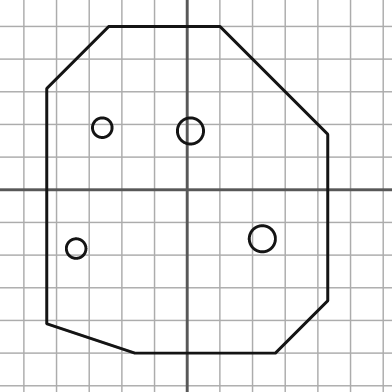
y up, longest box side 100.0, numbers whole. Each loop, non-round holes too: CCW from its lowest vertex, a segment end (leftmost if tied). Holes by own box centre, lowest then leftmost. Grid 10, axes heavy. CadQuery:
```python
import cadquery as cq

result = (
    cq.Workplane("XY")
    .moveTo(-16.0, -50.0)
    .lineTo(27.0, -50.0)
    .lineTo(43.0, -34.0)
    .lineTo(43.0, 17.0)
    .lineTo(10.0, 50.0)
    .lineTo(-24.0, 50.0)
    .lineTo(-43.0, 31.0)
    .lineTo(-43.0, -41.0)
    .close()
    .moveTo(-34.0, -18.0)
    .circle(3.0)
    .moveTo(23.0, -15.0)
    .circle(4.0)
    .moveTo(1.0, 18.0)
    .circle(4.0)
    .moveTo(-26.0, 19.0)
    .circle(3.0)
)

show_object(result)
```